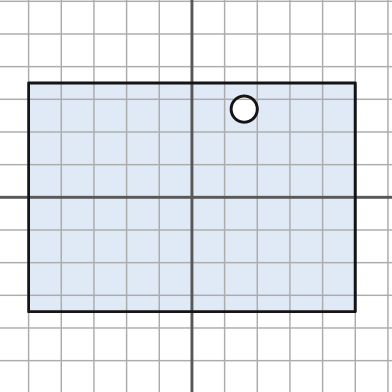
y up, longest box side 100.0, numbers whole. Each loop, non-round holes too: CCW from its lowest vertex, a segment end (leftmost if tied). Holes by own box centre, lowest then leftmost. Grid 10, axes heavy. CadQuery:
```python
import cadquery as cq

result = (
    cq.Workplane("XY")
    .moveTo(-50.0, -35.0)
    .lineTo(50.0, -35.0)
    .lineTo(50.0, 35.0)
    .lineTo(-50.0, 35.0)
    .close()
    .moveTo(16.0, 27.0)
    .circle(4.0)
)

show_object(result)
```